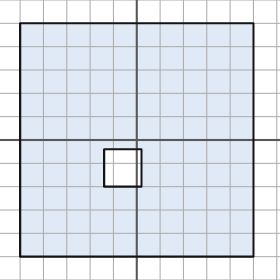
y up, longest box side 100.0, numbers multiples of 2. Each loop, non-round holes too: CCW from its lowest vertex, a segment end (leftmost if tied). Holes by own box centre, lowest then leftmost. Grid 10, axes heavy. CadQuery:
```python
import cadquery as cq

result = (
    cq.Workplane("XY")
    .moveTo(-50.0, -50.0)
    .lineTo(50.0, -50.0)
    .lineTo(50.0, 50.0)
    .lineTo(-50.0, 50.0)
    .close()
    .moveTo(-14.0, -20.0)
    .lineTo(2.0, -20.0)
    .lineTo(2.0, -4.0)
    .lineTo(-14.0, -4.0)
    .close()
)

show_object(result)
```